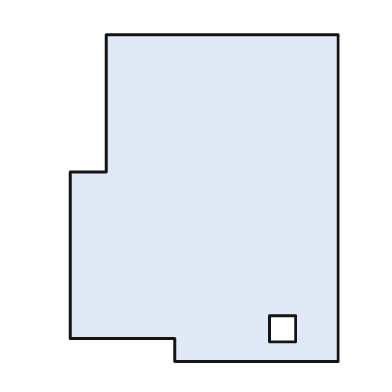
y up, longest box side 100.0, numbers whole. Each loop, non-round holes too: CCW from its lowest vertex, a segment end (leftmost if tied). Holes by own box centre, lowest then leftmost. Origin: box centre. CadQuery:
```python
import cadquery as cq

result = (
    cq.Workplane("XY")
    .moveTo(-9.0, -50.0)
    .lineTo(41.0, -50.0)
    .lineTo(41.0, 50.0)
    .lineTo(-30.0, 50.0)
    .lineTo(-30.0, 8.0)
    .lineTo(-41.0, 8.0)
    .lineTo(-41.0, -43.0)
    .lineTo(-9.0, -43.0)
    .close()
    .moveTo(20.0, -44.0)
    .lineTo(28.0, -44.0)
    .lineTo(28.0, -36.0)
    .lineTo(20.0, -36.0)
    .close()
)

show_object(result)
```